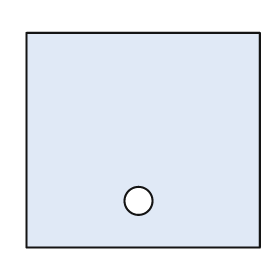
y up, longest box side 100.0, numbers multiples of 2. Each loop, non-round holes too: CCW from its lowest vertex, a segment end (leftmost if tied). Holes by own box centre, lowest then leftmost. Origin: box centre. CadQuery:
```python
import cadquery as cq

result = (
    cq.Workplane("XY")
    .moveTo(-50.0, -46.0)
    .lineTo(50.0, -46.0)
    .lineTo(50.0, 46.0)
    .lineTo(-50.0, 46.0)
    .close()
    .moveTo(-2.0, -26.0)
    .circle(6.0)
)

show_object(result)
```